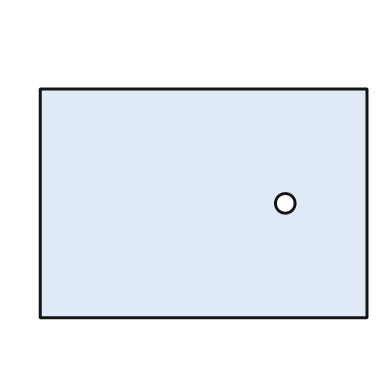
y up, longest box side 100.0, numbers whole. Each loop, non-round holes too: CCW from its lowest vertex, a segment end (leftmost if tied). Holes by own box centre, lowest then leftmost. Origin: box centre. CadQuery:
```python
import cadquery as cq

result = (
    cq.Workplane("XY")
    .moveTo(-50.0, -35.0)
    .lineTo(50.0, -35.0)
    .lineTo(50.0, 35.0)
    .lineTo(-50.0, 35.0)
    .close()
    .moveTo(25.0, 0.0)
    .circle(3.0)
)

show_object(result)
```